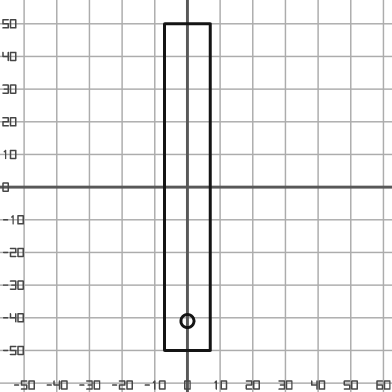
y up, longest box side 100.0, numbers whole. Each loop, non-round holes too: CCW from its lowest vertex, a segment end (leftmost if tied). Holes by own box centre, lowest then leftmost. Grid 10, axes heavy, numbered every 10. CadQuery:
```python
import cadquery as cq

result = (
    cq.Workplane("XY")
    .moveTo(-7.0, -50.0)
    .lineTo(7.0, -50.0)
    .lineTo(7.0, 50.0)
    .lineTo(-7.0, 50.0)
    .close()
    .moveTo(0.0, -41.0)
    .circle(2.0)
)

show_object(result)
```